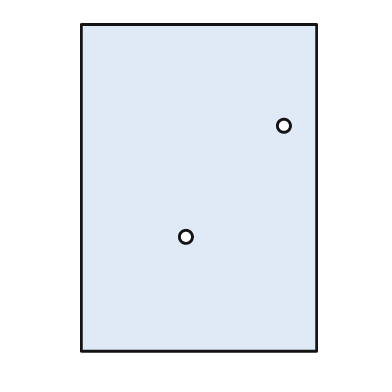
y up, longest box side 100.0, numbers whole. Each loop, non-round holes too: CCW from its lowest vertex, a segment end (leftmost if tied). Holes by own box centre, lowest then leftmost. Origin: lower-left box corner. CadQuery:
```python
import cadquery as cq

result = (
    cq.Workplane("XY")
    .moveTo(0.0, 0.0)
    .lineTo(72.0, 0.0)
    .lineTo(72.0, 100.0)
    .lineTo(0.0, 100.0)
    .close()
    .moveTo(32.0, 35.0)
    .circle(2.0)
    .moveTo(62.0, 69.0)
    .circle(2.0)
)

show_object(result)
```